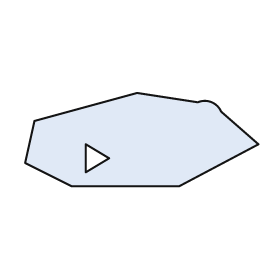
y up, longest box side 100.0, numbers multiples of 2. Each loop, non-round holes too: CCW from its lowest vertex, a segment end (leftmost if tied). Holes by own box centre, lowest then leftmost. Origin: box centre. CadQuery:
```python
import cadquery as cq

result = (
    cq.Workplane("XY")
    .moveTo(-30.0, -20.0)
    .lineTo(16.0, -20.0)
    .lineTo(50.0, -2.0)
    .lineTo(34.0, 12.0)
    .threePointArc((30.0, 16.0), (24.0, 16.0))
    .lineTo(-2.0, 20.0)
    .lineTo(-46.0, 8.0)
    .lineTo(-50.0, -10.0)
    .close()
    .moveTo(-24.0, -14.0)
    .lineTo(-14.0, -8.0)
    .lineTo(-24.0, -2.0)
    .close()
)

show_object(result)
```